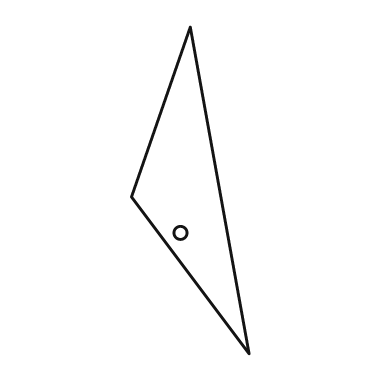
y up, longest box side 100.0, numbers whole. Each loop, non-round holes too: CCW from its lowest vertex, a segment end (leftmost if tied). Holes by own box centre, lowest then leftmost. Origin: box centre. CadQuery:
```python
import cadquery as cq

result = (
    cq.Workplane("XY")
    .moveTo(18.0, -50.0)
    .lineTo(0.0, 50.0)
    .lineTo(-18.0, -2.0)
    .close()
    .moveTo(-3.0, -13.0)
    .circle(2.0)
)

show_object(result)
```